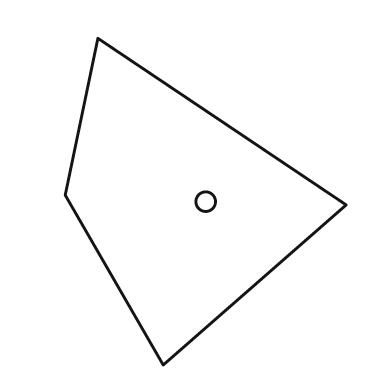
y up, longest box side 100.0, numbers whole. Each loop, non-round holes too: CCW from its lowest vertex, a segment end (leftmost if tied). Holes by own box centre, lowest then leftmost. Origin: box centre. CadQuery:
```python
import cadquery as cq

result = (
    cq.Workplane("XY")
    .moveTo(-13.0, -50.0)
    .lineTo(43.0, -1.0)
    .lineTo(-33.0, 50.0)
    .lineTo(-43.0, 2.0)
    .close()
    .moveTo(0.0, 0.0)
    .circle(3.0)
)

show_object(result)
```